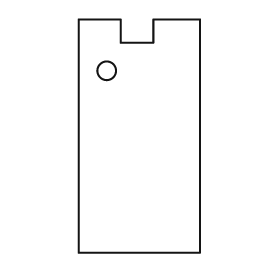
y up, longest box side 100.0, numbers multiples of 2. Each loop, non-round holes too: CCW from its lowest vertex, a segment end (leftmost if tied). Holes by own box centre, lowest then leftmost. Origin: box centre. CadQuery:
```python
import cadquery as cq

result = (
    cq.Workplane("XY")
    .moveTo(-26.0, -50.0)
    .lineTo(26.0, -50.0)
    .lineTo(26.0, 50.0)
    .lineTo(6.0, 50.0)
    .lineTo(6.0, 40.0)
    .lineTo(-8.0, 40.0)
    .lineTo(-8.0, 50.0)
    .lineTo(-26.0, 50.0)
    .close()
    .moveTo(-14.0, 28.0)
    .circle(4.0)
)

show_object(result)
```